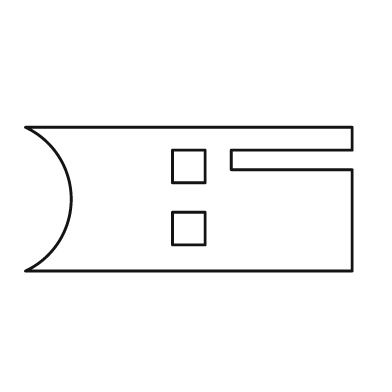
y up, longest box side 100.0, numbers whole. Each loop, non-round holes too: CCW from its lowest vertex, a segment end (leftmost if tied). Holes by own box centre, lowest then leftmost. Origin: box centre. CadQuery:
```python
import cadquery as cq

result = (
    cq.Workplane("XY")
    .moveTo(-50.0, -22.0)
    .lineTo(50.0, -22.0)
    .lineTo(50.0, 9.0)
    .lineTo(13.0, 9.0)
    .lineTo(13.0, 15.0)
    .lineTo(50.0, 15.0)
    .lineTo(50.0, 22.0)
    .lineTo(-50.0, 22.0)
    .threePointArc((-36.0, 0.0), (-50.0, -22.0))
    .close()
    .moveTo(-5.0, -14.0)
    .lineTo(5.0, -14.0)
    .lineTo(5.0, -4.0)
    .lineTo(-5.0, -4.0)
    .close()
    .moveTo(-5.0, 5.0)
    .lineTo(5.0, 5.0)
    .lineTo(5.0, 15.0)
    .lineTo(-5.0, 15.0)
    .close()
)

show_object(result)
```